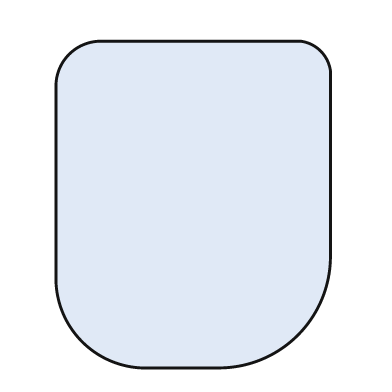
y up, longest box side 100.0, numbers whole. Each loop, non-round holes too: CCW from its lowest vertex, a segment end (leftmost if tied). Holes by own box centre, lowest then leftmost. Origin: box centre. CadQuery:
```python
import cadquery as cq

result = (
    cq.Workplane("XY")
    .moveTo(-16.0, -50.0)
    .lineTo(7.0, -50.0)
    .threePointArc((32.0, -40.0), (42.0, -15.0))
    .lineTo(42.0, 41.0)
    .threePointArc((39.0, 47.0), (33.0, 50.0))
    .lineTo(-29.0, 50.0)
    .threePointArc((-38.0, 46.0), (-42.0, 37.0))
    .lineTo(-42.0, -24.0)
    .threePointArc((-34.0, -42.0), (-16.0, -50.0))
    .close()
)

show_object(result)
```